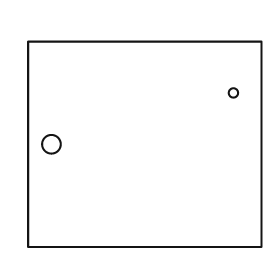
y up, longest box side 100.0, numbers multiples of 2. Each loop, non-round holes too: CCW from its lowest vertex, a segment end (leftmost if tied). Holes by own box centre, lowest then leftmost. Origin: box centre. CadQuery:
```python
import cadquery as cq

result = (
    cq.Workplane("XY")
    .moveTo(-50.0, -44.0)
    .lineTo(50.0, -44.0)
    .lineTo(50.0, 44.0)
    .lineTo(-50.0, 44.0)
    .close()
    .moveTo(-40.0, 0.0)
    .circle(4.0)
    .moveTo(38.0, 22.0)
    .circle(2.0)
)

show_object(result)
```